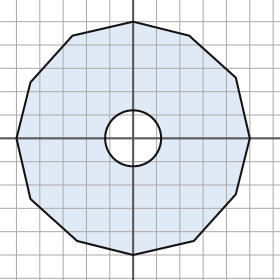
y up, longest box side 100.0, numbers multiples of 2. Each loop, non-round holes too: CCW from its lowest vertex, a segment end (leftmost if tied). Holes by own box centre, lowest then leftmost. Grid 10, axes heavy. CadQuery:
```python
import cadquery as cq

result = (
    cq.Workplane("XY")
    .moveTo(0.0, -50.0)
    .lineTo(26.0, -44.0)
    .lineTo(44.0, -24.0)
    .lineTo(50.0, 0.0)
    .lineTo(44.0, 26.0)
    .lineTo(24.0, 44.0)
    .lineTo(0.0, 50.0)
    .lineTo(-26.0, 44.0)
    .lineTo(-44.0, 24.0)
    .lineTo(-50.0, 0.0)
    .lineTo(-44.0, -26.0)
    .lineTo(-24.0, -44.0)
    .close()
    .moveTo(0.0, 0.0)
    .circle(12.0)
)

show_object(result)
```